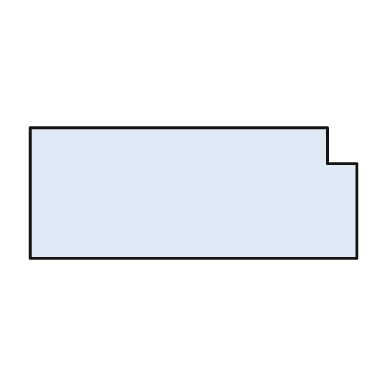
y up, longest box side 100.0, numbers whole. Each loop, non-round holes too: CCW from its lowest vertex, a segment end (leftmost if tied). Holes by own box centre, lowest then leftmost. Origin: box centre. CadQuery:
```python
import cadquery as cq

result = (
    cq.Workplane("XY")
    .moveTo(-50.0, -20.0)
    .lineTo(50.0, -20.0)
    .lineTo(50.0, 9.0)
    .lineTo(41.0, 9.0)
    .lineTo(41.0, 20.0)
    .lineTo(-50.0, 20.0)
    .close()
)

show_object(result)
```